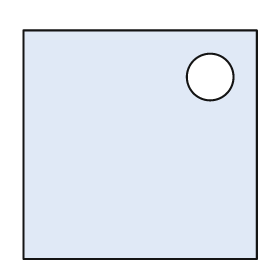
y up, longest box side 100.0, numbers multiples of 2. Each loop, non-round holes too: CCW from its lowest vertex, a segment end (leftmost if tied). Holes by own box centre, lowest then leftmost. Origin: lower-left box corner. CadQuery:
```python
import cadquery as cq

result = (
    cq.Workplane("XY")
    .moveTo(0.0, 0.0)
    .lineTo(100.0, 0.0)
    .lineTo(100.0, 98.0)
    .lineTo(0.0, 98.0)
    .close()
    .moveTo(80.0, 78.0)
    .circle(10.0)
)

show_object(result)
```